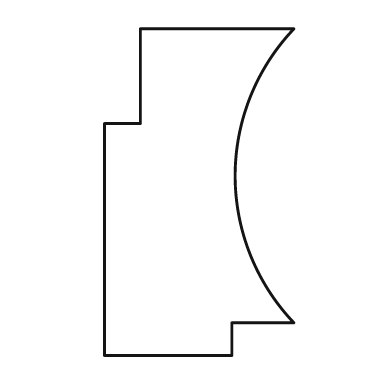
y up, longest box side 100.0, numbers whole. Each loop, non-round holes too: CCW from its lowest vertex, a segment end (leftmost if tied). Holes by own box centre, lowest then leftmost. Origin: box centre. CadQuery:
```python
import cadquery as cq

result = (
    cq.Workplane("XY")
    .moveTo(-29.0, -50.0)
    .lineTo(10.0, -50.0)
    .lineTo(10.0, -40.0)
    .lineTo(29.0, -40.0)
    .threePointArc((11.0, 5.0), (29.0, 50.0))
    .lineTo(-18.0, 50.0)
    .lineTo(-18.0, 21.0)
    .lineTo(-29.0, 21.0)
    .close()
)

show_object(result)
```